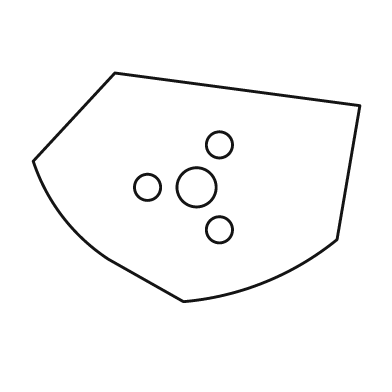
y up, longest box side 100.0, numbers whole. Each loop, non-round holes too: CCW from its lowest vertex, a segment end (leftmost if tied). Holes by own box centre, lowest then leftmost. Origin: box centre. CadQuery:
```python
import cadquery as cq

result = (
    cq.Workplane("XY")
    .moveTo(-4.0, -35.0)
    .threePointArc((21.0, -29.0), (43.0, -16.0))
    .lineTo(50.0, 25.0)
    .lineTo(-25.0, 35.0)
    .lineTo(-50.0, 8.0)
    .threePointArc((-41.0, -9.0), (-27.0, -22.0))
    .close()
    .moveTo(7.0, -13.0)
    .circle(4.0)
    .moveTo(-15.0, 0.0)
    .circle(4.0)
    .moveTo(0.0, 0.0)
    .circle(6.0)
    .moveTo(7.0, 13.0)
    .circle(4.0)
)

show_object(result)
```